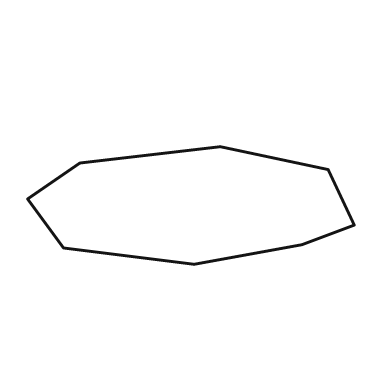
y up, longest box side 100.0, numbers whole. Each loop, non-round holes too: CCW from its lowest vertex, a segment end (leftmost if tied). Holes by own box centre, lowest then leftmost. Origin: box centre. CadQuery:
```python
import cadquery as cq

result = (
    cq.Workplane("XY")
    .moveTo(1.0, -18.0)
    .lineTo(34.0, -12.0)
    .lineTo(50.0, -6.0)
    .lineTo(42.0, 11.0)
    .lineTo(9.0, 18.0)
    .lineTo(-34.0, 13.0)
    .lineTo(-50.0, 2.0)
    .lineTo(-39.0, -13.0)
    .close()
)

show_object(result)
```